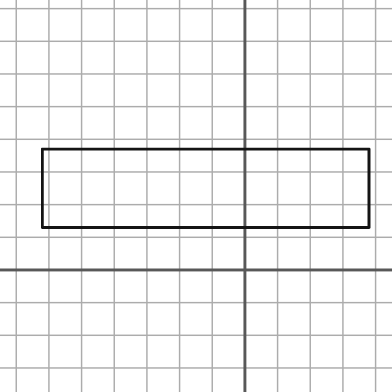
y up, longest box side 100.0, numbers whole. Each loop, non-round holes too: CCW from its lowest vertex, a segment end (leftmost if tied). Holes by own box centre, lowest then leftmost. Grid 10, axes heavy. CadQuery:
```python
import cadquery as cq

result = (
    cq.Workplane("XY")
    .moveTo(-62.0, 13.0)
    .lineTo(38.0, 13.0)
    .lineTo(38.0, 37.0)
    .lineTo(-62.0, 37.0)
    .close()
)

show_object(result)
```